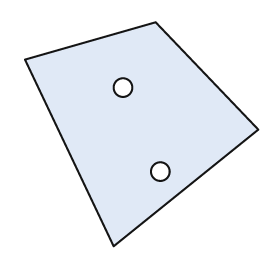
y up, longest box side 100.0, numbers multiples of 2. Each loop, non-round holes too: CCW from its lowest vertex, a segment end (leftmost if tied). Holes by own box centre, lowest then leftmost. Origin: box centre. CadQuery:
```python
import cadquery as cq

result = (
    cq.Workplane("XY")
    .moveTo(-12.0, -48.0)
    .lineTo(50.0, 2.0)
    .lineTo(6.0, 48.0)
    .lineTo(-50.0, 32.0)
    .close()
    .moveTo(8.0, -16.0)
    .circle(4.0)
    .moveTo(-8.0, 20.0)
    .circle(4.0)
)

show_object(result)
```